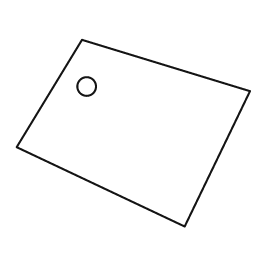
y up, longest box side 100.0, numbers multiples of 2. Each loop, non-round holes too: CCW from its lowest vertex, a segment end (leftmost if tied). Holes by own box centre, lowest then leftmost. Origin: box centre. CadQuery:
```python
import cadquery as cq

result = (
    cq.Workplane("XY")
    .moveTo(22.0, -40.0)
    .lineTo(50.0, 18.0)
    .lineTo(-22.0, 40.0)
    .lineTo(-50.0, -6.0)
    .close()
    .moveTo(-20.0, 20.0)
    .circle(4.0)
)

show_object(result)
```